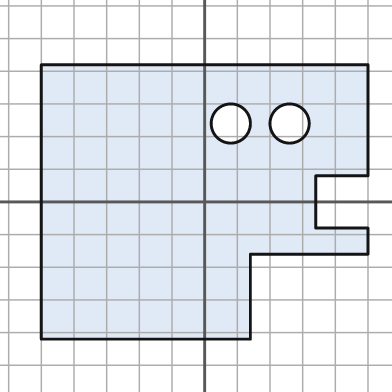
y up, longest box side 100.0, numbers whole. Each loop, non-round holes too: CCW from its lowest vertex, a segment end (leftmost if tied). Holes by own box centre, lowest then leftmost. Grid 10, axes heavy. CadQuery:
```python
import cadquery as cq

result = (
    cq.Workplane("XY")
    .moveTo(-50.0, -42.0)
    .lineTo(14.0, -42.0)
    .lineTo(14.0, -16.0)
    .lineTo(50.0, -16.0)
    .lineTo(50.0, -8.0)
    .lineTo(34.0, -8.0)
    .lineTo(34.0, 8.0)
    .lineTo(50.0, 8.0)
    .lineTo(50.0, 42.0)
    .lineTo(-50.0, 42.0)
    .close()
    .moveTo(8.0, 24.0)
    .circle(6.0)
    .moveTo(26.0, 24.0)
    .circle(6.0)
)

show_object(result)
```